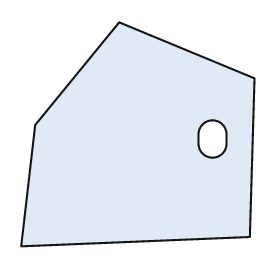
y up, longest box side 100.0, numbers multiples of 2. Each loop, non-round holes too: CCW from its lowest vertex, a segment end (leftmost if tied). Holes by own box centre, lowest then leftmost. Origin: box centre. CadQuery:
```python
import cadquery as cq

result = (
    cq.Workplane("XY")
    .moveTo(-50.0, -48.0)
    .lineTo(48.0, -44.0)
    .lineTo(50.0, 24.0)
    .lineTo(-8.0, 48.0)
    .lineTo(-44.0, 4.0)
    .close()
    .moveTo(26.0, -4.0)
    .threePointArc((32.0, -10.0), (38.0, -4.0))
    .lineTo(38.0, 0.0)
    .threePointArc((32.0, 6.0), (26.0, 0.0))
    .close()
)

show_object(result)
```